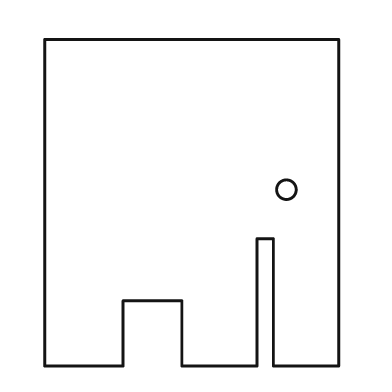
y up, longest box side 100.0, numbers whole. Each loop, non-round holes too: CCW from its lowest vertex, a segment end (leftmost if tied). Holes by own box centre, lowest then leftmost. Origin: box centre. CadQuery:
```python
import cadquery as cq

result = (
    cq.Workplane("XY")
    .moveTo(-45.0, -50.0)
    .lineTo(-21.0, -50.0)
    .lineTo(-21.0, -30.0)
    .lineTo(-3.0, -30.0)
    .lineTo(-3.0, -50.0)
    .lineTo(20.0, -50.0)
    .lineTo(20.0, -11.0)
    .lineTo(25.0, -11.0)
    .lineTo(25.0, -50.0)
    .lineTo(45.0, -50.0)
    .lineTo(45.0, 50.0)
    .lineTo(-45.0, 50.0)
    .close()
    .moveTo(29.0, 4.0)
    .circle(3.0)
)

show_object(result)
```